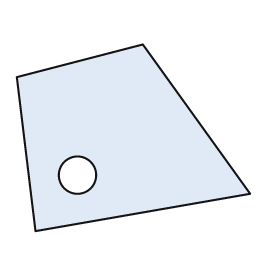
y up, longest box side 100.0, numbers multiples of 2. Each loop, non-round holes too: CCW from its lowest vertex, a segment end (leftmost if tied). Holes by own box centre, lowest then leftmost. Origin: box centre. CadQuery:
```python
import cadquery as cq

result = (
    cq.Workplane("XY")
    .moveTo(-42.0, -40.0)
    .lineTo(50.0, -24.0)
    .lineTo(4.0, 40.0)
    .lineTo(-50.0, 26.0)
    .close()
    .moveTo(-24.0, -16.0)
    .circle(8.0)
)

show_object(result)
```